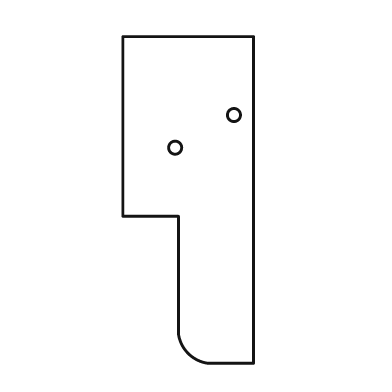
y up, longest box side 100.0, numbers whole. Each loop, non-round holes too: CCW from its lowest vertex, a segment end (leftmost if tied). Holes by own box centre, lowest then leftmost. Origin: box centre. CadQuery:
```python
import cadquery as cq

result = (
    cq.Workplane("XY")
    .moveTo(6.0, -50.0)
    .lineTo(20.0, -50.0)
    .lineTo(20.0, 50.0)
    .lineTo(-20.0, 50.0)
    .lineTo(-20.0, -5.0)
    .lineTo(-3.0, -5.0)
    .lineTo(-3.0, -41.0)
    .threePointArc((0.0, -47.0), (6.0, -50.0))
    .close()
    .moveTo(-4.0, 16.0)
    .circle(2.0)
    .moveTo(14.0, 26.0)
    .circle(2.0)
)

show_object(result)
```